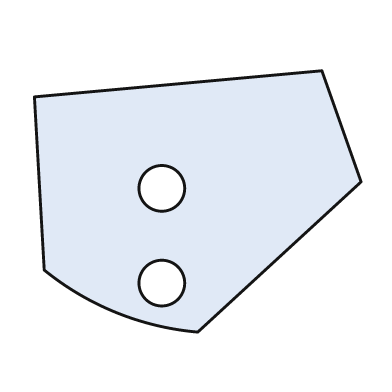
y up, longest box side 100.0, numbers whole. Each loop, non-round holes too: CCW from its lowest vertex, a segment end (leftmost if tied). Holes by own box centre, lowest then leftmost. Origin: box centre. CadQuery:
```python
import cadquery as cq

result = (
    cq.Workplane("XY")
    .moveTo(0.0, -40.0)
    .lineTo(50.0, 6.0)
    .lineTo(38.0, 40.0)
    .lineTo(-50.0, 32.0)
    .lineTo(-47.0, -21.0)
    .threePointArc((-25.0, -34.0), (0.0, -40.0))
    .close()
    .moveTo(-11.0, -25.0)
    .circle(7.0)
    .moveTo(-11.0, 4.0)
    .circle(7.0)
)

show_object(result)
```